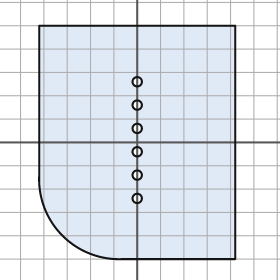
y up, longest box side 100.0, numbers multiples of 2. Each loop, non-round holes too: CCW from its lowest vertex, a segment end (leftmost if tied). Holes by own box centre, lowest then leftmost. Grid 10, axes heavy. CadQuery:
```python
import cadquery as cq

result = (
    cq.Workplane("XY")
    .moveTo(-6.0, -50.0)
    .lineTo(42.0, -50.0)
    .lineTo(42.0, 50.0)
    .lineTo(-42.0, 50.0)
    .lineTo(-42.0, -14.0)
    .threePointArc((-32.0, -40.0), (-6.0, -50.0))
    .close()
    .moveTo(0.0, -24.0)
    .circle(2.0)
    .moveTo(0.0, -14.0)
    .circle(2.0)
    .moveTo(0.0, -4.0)
    .circle(2.0)
    .moveTo(0.0, 6.0)
    .circle(2.0)
    .moveTo(0.0, 16.0)
    .circle(2.0)
    .moveTo(0.0, 26.0)
    .circle(2.0)
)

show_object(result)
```